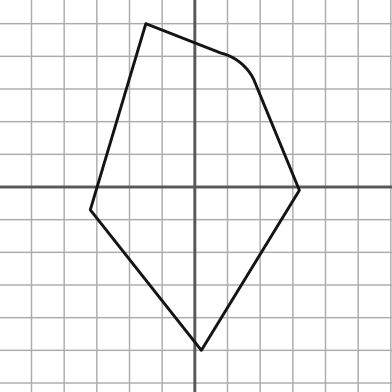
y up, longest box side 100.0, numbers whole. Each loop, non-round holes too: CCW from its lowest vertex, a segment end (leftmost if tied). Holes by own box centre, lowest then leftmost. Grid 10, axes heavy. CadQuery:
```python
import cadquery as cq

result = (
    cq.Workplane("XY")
    .moveTo(2.0, -50.0)
    .lineTo(32.0, -1.0)
    .lineTo(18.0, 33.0)
    .threePointArc((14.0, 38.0), (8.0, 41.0))
    .lineTo(-15.0, 50.0)
    .lineTo(-32.0, -7.0)
    .close()
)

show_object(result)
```